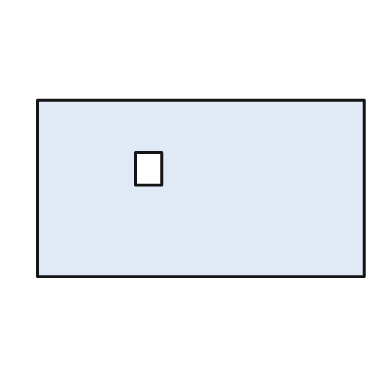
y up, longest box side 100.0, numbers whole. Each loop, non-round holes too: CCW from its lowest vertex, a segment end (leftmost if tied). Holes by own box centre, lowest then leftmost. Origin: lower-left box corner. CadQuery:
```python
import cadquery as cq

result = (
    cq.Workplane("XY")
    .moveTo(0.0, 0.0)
    .lineTo(100.0, 0.0)
    .lineTo(100.0, 54.0)
    .lineTo(0.0, 54.0)
    .close()
    .moveTo(30.0, 28.0)
    .lineTo(38.0, 28.0)
    .lineTo(38.0, 38.0)
    .lineTo(30.0, 38.0)
    .close()
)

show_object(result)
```